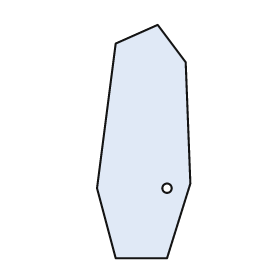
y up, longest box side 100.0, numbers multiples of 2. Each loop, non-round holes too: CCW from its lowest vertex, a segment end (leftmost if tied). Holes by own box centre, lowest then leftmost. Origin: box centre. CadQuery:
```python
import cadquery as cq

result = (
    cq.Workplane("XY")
    .moveTo(-12.0, -50.0)
    .lineTo(10.0, -50.0)
    .lineTo(20.0, -18.0)
    .lineTo(18.0, 34.0)
    .lineTo(6.0, 50.0)
    .lineTo(-12.0, 42.0)
    .lineTo(-20.0, -20.0)
    .close()
    .moveTo(10.0, -20.0)
    .circle(2.0)
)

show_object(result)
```